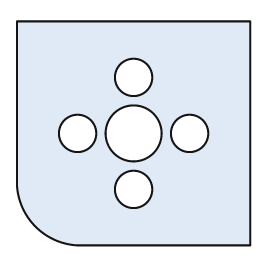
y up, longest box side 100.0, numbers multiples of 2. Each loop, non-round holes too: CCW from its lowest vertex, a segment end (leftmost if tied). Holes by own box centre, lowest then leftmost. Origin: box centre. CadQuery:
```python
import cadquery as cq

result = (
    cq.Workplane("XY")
    .moveTo(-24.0, -48.0)
    .lineTo(50.0, -48.0)
    .lineTo(50.0, 48.0)
    .lineTo(-50.0, 48.0)
    .lineTo(-50.0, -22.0)
    .threePointArc((-42.0, -40.0), (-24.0, -48.0))
    .close()
    .moveTo(0.0, -24.0)
    .circle(8.0)
    .moveTo(-24.0, 0.0)
    .circle(8.0)
    .moveTo(0.0, 0.0)
    .circle(12.0)
    .moveTo(24.0, 0.0)
    .circle(8.0)
    .moveTo(0.0, 24.0)
    .circle(8.0)
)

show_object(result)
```